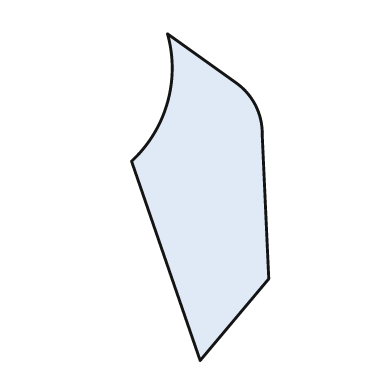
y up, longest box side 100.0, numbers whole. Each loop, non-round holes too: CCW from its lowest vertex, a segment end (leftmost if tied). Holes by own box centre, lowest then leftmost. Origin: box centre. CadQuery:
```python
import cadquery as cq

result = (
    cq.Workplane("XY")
    .moveTo(0.0, -50.0)
    .lineTo(21.0, -25.0)
    .lineTo(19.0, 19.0)
    .threePointArc((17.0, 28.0), (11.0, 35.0))
    .lineTo(-10.0, 50.0)
    .threePointArc((-10.0, 29.0), (-21.0, 11.0))
    .close()
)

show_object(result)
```